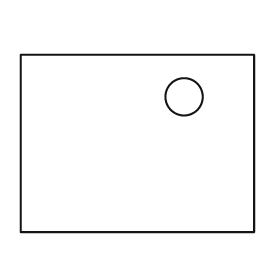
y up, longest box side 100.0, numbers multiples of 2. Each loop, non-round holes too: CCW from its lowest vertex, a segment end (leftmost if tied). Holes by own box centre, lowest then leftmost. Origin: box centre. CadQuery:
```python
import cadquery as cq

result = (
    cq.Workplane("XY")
    .moveTo(-50.0, -38.0)
    .lineTo(50.0, -38.0)
    .lineTo(50.0, 38.0)
    .lineTo(-50.0, 38.0)
    .close()
    .moveTo(20.0, 20.0)
    .circle(8.0)
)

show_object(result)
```